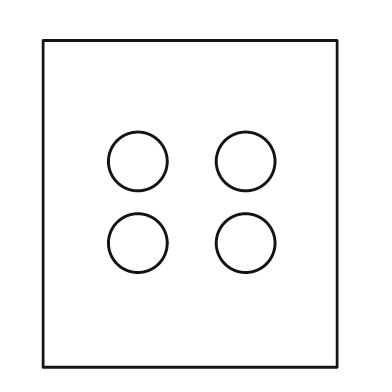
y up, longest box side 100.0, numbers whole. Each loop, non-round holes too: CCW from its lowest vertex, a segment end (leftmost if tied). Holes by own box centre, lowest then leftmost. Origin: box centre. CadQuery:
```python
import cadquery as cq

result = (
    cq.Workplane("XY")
    .moveTo(-45.0, -50.0)
    .lineTo(45.0, -50.0)
    .lineTo(45.0, 50.0)
    .lineTo(-45.0, 50.0)
    .close()
    .moveTo(-16.0, -12.0)
    .circle(9.0)
    .moveTo(17.0, -12.0)
    .circle(9.0)
    .moveTo(-16.0, 13.0)
    .circle(9.0)
    .moveTo(17.0, 13.0)
    .circle(9.0)
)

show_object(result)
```